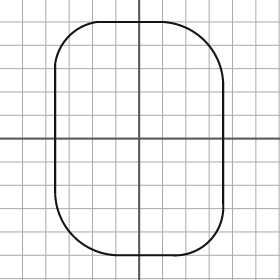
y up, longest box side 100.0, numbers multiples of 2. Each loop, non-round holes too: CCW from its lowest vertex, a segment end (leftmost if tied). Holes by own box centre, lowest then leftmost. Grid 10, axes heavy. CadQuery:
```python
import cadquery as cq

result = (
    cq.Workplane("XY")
    .moveTo(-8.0, -50.0)
    .lineTo(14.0, -50.0)
    .threePointArc((30.0, -44.0), (36.0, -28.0))
    .lineTo(36.0, 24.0)
    .threePointArc((28.0, 42.0), (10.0, 50.0))
    .lineTo(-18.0, 50.0)
    .threePointArc((-30.0, 44.0), (-36.0, 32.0))
    .lineTo(-36.0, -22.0)
    .threePointArc((-28.0, -42.0), (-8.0, -50.0))
    .close()
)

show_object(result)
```